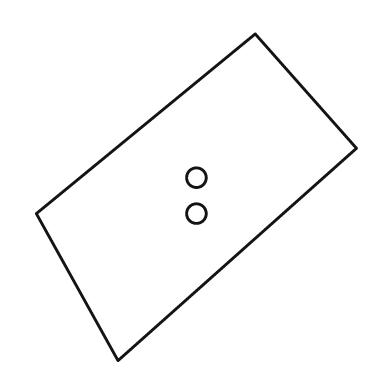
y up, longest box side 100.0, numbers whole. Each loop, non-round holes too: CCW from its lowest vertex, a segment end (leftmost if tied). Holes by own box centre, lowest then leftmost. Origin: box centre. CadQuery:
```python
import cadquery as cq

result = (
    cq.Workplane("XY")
    .moveTo(-24.0, -50.0)
    .lineTo(49.0, 15.0)
    .lineTo(18.0, 50.0)
    .lineTo(-49.0, -5.0)
    .close()
    .moveTo(0.0, -5.0)
    .circle(3.0)
    .moveTo(0.0, 6.0)
    .circle(3.0)
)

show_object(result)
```